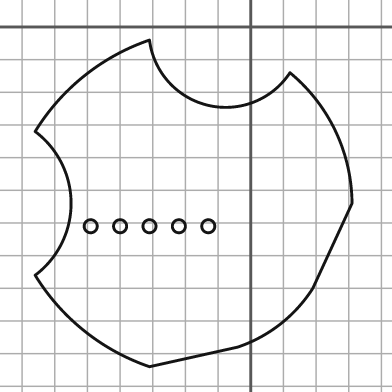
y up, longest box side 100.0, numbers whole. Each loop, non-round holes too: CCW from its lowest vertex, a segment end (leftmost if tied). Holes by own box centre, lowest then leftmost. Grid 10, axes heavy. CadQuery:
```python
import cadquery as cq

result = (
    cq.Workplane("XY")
    .moveTo(-31.0, -104.0)
    .lineTo(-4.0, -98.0)
    .threePointArc((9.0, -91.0), (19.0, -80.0))
    .lineTo(31.0, -54.0)
    .threePointArc((26.0, -32.0), (12.0, -14.0))
    .threePointArc((-13.0, -24.0), (-31.0, -4.0))
    .threePointArc((-51.0, -15.0), (-66.0, -32.0))
    .threePointArc((-55.0, -54.0), (-66.0, -76.0))
    .threePointArc((-51.0, -93.0), (-31.0, -104.0))
    .close()
    .moveTo(-49.0, -61.0)
    .circle(2.0)
    .moveTo(-40.0, -61.0)
    .circle(2.0)
    .moveTo(-31.0, -61.0)
    .circle(2.0)
    .moveTo(-22.0, -61.0)
    .circle(2.0)
    .moveTo(-13.0, -61.0)
    .circle(2.0)
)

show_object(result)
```